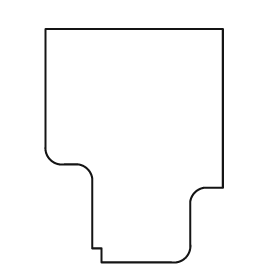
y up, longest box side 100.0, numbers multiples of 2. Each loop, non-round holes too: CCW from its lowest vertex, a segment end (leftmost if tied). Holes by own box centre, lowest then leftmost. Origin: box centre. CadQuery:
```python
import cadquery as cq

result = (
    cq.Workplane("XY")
    .moveTo(-14.0, -50.0)
    .lineTo(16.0, -50.0)
    .threePointArc((22.0, -48.0), (24.0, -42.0))
    .lineTo(24.0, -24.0)
    .threePointArc((26.0, -20.0), (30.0, -18.0))
    .lineTo(38.0, -18.0)
    .lineTo(38.0, 50.0)
    .lineTo(-38.0, 50.0)
    .lineTo(-38.0, 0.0)
    .threePointArc((-36.0, -6.0), (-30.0, -8.0))
    .lineTo(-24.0, -8.0)
    .threePointArc((-20.0, -10.0), (-18.0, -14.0))
    .lineTo(-18.0, -44.0)
    .lineTo(-14.0, -44.0)
    .close()
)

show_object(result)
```